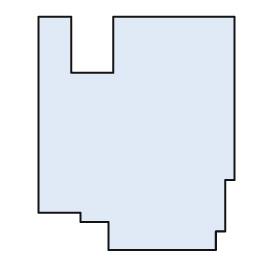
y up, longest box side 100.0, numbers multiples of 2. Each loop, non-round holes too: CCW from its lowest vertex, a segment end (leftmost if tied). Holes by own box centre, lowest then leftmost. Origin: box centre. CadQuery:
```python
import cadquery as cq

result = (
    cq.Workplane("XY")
    .moveTo(-12.0, -50.0)
    .lineTo(34.0, -50.0)
    .lineTo(34.0, -42.0)
    .lineTo(38.0, -42.0)
    .lineTo(38.0, -20.0)
    .lineTo(42.0, -20.0)
    .lineTo(42.0, 50.0)
    .lineTo(-10.0, 50.0)
    .lineTo(-10.0, 26.0)
    .lineTo(-28.0, 26.0)
    .lineTo(-28.0, 50.0)
    .lineTo(-42.0, 50.0)
    .lineTo(-42.0, -34.0)
    .lineTo(-24.0, -34.0)
    .lineTo(-24.0, -38.0)
    .lineTo(-12.0, -38.0)
    .close()
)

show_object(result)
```